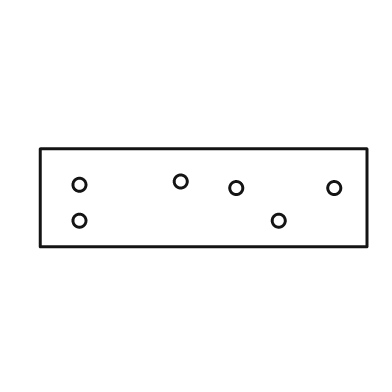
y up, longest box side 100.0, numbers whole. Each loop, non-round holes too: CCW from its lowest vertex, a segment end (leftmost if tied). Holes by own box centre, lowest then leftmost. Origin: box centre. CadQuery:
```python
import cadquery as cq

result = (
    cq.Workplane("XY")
    .moveTo(-50.0, -15.0)
    .lineTo(50.0, -15.0)
    .lineTo(50.0, 15.0)
    .lineTo(-50.0, 15.0)
    .close()
    .moveTo(-38.0, -7.0)
    .circle(2.0)
    .moveTo(23.0, -7.0)
    .circle(2.0)
    .moveTo(10.0, 3.0)
    .circle(2.0)
    .moveTo(40.0, 3.0)
    .circle(2.0)
    .moveTo(-38.0, 4.0)
    .circle(2.0)
    .moveTo(-7.0, 5.0)
    .circle(2.0)
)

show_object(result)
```